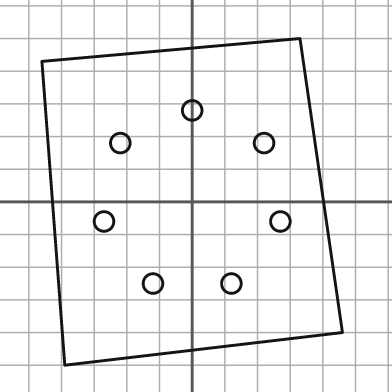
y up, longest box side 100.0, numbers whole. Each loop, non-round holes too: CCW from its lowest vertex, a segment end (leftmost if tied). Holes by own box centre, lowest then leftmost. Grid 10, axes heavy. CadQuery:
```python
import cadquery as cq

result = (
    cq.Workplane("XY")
    .moveTo(-39.0, -50.0)
    .lineTo(46.0, -40.0)
    .lineTo(33.0, 50.0)
    .lineTo(-46.0, 43.0)
    .close()
    .moveTo(-12.0, -25.0)
    .circle(3.0)
    .moveTo(12.0, -25.0)
    .circle(3.0)
    .moveTo(-27.0, -6.0)
    .circle(3.0)
    .moveTo(27.0, -6.0)
    .circle(3.0)
    .moveTo(-22.0, 18.0)
    .circle(3.0)
    .moveTo(22.0, 18.0)
    .circle(3.0)
    .moveTo(0.0, 28.0)
    .circle(3.0)
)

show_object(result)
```